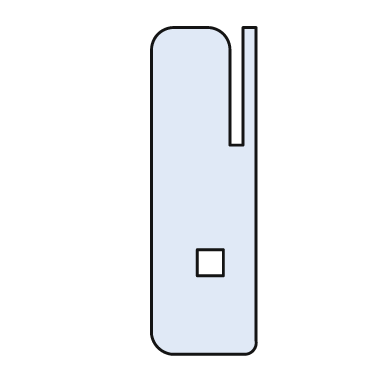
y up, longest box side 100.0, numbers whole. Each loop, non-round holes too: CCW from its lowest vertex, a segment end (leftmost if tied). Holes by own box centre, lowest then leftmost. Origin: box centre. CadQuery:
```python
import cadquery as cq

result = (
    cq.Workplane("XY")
    .moveTo(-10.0, -50.0)
    .lineTo(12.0, -50.0)
    .threePointArc((15.0, -49.0), (16.0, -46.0))
    .lineTo(16.0, 50.0)
    .lineTo(12.0, 50.0)
    .lineTo(12.0, 14.0)
    .lineTo(8.0, 14.0)
    .lineTo(8.0, 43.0)
    .threePointArc((6.0, 48.0), (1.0, 50.0))
    .lineTo(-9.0, 50.0)
    .threePointArc((-14.0, 48.0), (-16.0, 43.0))
    .lineTo(-16.0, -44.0)
    .threePointArc((-14.0, -48.0), (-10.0, -50.0))
    .close()
    .moveTo(-2.0, -26.0)
    .lineTo(6.0, -26.0)
    .lineTo(6.0, -18.0)
    .lineTo(-2.0, -18.0)
    .close()
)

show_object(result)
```